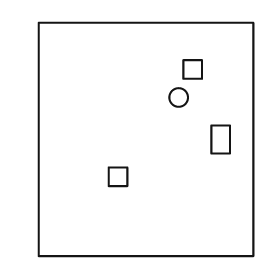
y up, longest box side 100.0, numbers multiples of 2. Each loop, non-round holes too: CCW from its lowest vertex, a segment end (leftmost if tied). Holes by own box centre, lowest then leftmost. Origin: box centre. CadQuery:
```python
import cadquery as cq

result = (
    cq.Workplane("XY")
    .moveTo(-46.0, -50.0)
    .lineTo(46.0, -50.0)
    .lineTo(46.0, 50.0)
    .lineTo(-46.0, 50.0)
    .close()
    .moveTo(-16.0, -20.0)
    .lineTo(-8.0, -20.0)
    .lineTo(-8.0, -12.0)
    .lineTo(-16.0, -12.0)
    .close()
    .moveTo(28.0, -6.0)
    .lineTo(36.0, -6.0)
    .lineTo(36.0, 6.0)
    .lineTo(28.0, 6.0)
    .close()
    .moveTo(14.0, 18.0)
    .circle(4.0)
    .moveTo(16.0, 26.0)
    .lineTo(24.0, 26.0)
    .lineTo(24.0, 34.0)
    .lineTo(16.0, 34.0)
    .close()
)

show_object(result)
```